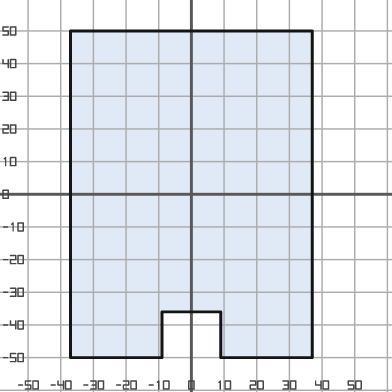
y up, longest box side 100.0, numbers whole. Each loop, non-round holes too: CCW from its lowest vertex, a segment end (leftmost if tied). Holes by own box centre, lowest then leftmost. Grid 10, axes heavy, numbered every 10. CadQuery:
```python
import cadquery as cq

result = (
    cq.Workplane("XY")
    .moveTo(-37.0, -50.0)
    .lineTo(-9.0, -50.0)
    .lineTo(-9.0, -36.0)
    .lineTo(9.0, -36.0)
    .lineTo(9.0, -50.0)
    .lineTo(37.0, -50.0)
    .lineTo(37.0, 50.0)
    .lineTo(-37.0, 50.0)
    .close()
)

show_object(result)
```